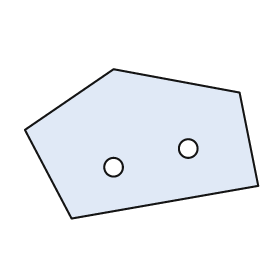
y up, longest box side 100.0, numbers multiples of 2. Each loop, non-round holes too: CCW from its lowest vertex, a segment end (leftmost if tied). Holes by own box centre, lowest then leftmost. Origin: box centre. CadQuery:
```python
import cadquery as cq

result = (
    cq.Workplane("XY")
    .moveTo(-30.0, -32.0)
    .lineTo(50.0, -18.0)
    .lineTo(42.0, 22.0)
    .lineTo(-12.0, 32.0)
    .lineTo(-50.0, 6.0)
    .close()
    .moveTo(-12.0, -10.0)
    .circle(4.0)
    .moveTo(20.0, -2.0)
    .circle(4.0)
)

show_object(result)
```